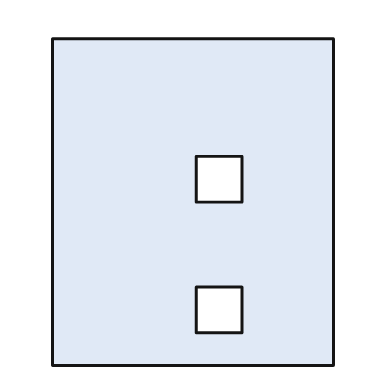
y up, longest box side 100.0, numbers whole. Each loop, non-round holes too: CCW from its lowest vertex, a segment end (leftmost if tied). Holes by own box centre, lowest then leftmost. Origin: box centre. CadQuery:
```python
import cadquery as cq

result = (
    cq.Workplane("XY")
    .moveTo(-43.0, -50.0)
    .lineTo(43.0, -50.0)
    .lineTo(43.0, 50.0)
    .lineTo(-43.0, 50.0)
    .close()
    .moveTo(1.0, -40.0)
    .lineTo(15.0, -40.0)
    .lineTo(15.0, -26.0)
    .lineTo(1.0, -26.0)
    .close()
    .moveTo(1.0, 0.0)
    .lineTo(15.0, 0.0)
    .lineTo(15.0, 14.0)
    .lineTo(1.0, 14.0)
    .close()
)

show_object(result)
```